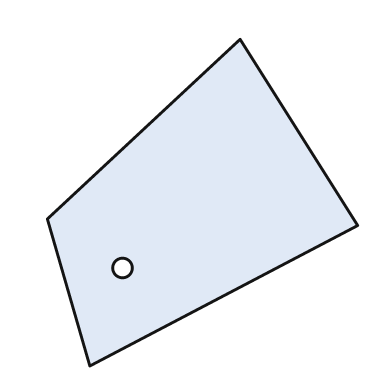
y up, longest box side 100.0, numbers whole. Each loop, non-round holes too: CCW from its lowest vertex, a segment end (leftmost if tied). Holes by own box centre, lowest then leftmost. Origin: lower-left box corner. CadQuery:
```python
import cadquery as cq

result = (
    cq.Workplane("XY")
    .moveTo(13.0, 0.0)
    .lineTo(95.0, 43.0)
    .lineTo(59.0, 100.0)
    .lineTo(0.0, 45.0)
    .close()
    .moveTo(23.0, 30.0)
    .circle(3.0)
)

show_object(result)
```